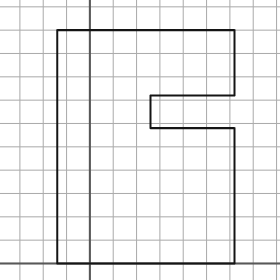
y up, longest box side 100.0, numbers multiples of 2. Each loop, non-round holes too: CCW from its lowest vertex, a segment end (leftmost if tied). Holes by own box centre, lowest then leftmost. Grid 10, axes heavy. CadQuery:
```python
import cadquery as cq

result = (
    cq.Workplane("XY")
    .moveTo(-14.0, 0.0)
    .lineTo(62.0, 0.0)
    .lineTo(62.0, 58.0)
    .lineTo(26.0, 58.0)
    .lineTo(26.0, 72.0)
    .lineTo(62.0, 72.0)
    .lineTo(62.0, 100.0)
    .lineTo(-14.0, 100.0)
    .close()
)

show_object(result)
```